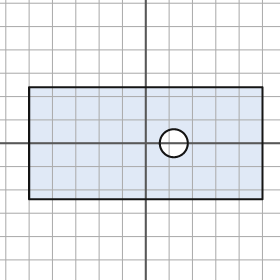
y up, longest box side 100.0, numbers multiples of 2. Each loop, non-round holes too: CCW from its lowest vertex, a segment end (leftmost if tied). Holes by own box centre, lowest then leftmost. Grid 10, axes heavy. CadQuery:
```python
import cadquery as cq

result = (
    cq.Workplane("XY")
    .moveTo(-50.0, -24.0)
    .lineTo(50.0, -24.0)
    .lineTo(50.0, 24.0)
    .lineTo(-50.0, 24.0)
    .close()
    .moveTo(12.0, 0.0)
    .circle(6.0)
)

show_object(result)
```